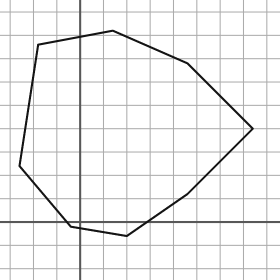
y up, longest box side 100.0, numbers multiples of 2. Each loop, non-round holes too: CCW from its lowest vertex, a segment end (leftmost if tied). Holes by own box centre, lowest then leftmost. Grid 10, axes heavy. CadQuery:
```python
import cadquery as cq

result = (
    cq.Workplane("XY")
    .moveTo(20.0, -6.0)
    .lineTo(46.0, 12.0)
    .lineTo(74.0, 40.0)
    .lineTo(46.0, 68.0)
    .lineTo(14.0, 82.0)
    .lineTo(-18.0, 76.0)
    .lineTo(-26.0, 24.0)
    .lineTo(-4.0, -2.0)
    .close()
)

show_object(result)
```